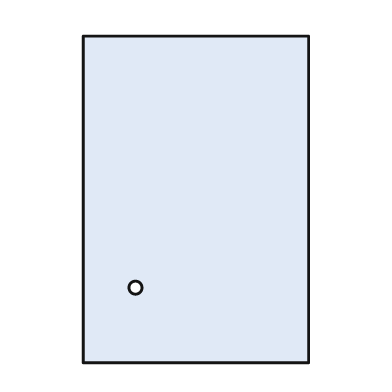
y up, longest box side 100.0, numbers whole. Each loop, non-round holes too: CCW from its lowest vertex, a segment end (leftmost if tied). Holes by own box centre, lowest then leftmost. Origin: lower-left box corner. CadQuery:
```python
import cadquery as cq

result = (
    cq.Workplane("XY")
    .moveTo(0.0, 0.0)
    .lineTo(69.0, 0.0)
    .lineTo(69.0, 100.0)
    .lineTo(0.0, 100.0)
    .close()
    .moveTo(16.0, 23.0)
    .circle(2.0)
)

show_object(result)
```